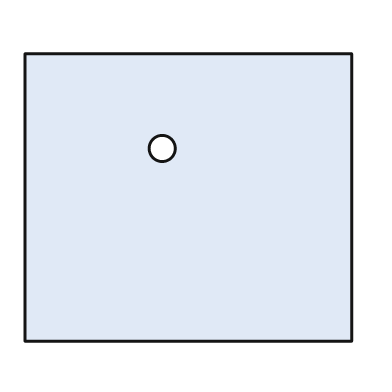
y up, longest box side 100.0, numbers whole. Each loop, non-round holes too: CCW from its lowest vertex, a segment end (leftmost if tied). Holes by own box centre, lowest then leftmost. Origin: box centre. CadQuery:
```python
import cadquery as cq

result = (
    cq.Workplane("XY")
    .moveTo(-50.0, -44.0)
    .lineTo(50.0, -44.0)
    .lineTo(50.0, 44.0)
    .lineTo(-50.0, 44.0)
    .close()
    .moveTo(-8.0, 15.0)
    .circle(4.0)
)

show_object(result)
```